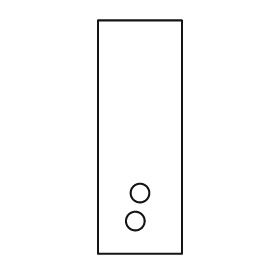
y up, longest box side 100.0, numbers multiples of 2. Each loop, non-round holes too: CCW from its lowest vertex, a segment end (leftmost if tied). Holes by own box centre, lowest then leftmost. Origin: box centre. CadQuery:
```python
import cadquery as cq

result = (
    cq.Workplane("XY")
    .moveTo(-18.0, -50.0)
    .lineTo(18.0, -50.0)
    .lineTo(18.0, 50.0)
    .lineTo(-18.0, 50.0)
    .close()
    .moveTo(-2.0, -36.0)
    .circle(4.0)
    .moveTo(0.0, -24.0)
    .circle(4.0)
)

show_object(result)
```